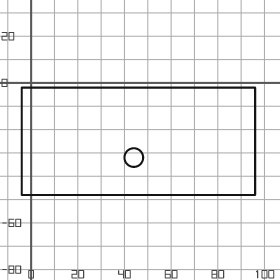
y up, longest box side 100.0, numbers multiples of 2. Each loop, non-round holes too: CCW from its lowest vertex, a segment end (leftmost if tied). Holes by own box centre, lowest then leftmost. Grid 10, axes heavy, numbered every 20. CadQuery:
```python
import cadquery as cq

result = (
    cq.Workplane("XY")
    .moveTo(-4.0, -48.0)
    .lineTo(96.0, -48.0)
    .lineTo(96.0, -2.0)
    .lineTo(-4.0, -2.0)
    .close()
    .moveTo(44.0, -32.0)
    .circle(4.0)
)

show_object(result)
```